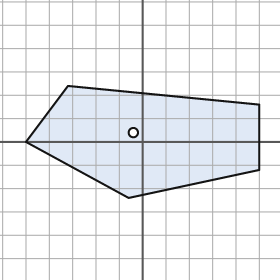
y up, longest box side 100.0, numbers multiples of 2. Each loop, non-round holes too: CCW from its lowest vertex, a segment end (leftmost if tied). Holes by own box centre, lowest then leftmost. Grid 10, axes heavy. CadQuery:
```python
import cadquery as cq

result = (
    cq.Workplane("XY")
    .moveTo(-6.0, -24.0)
    .lineTo(50.0, -12.0)
    .lineTo(50.0, 16.0)
    .lineTo(-32.0, 24.0)
    .lineTo(-50.0, 0.0)
    .close()
    .moveTo(-4.0, 4.0)
    .circle(2.0)
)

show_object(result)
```